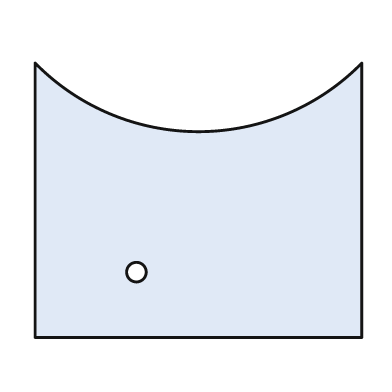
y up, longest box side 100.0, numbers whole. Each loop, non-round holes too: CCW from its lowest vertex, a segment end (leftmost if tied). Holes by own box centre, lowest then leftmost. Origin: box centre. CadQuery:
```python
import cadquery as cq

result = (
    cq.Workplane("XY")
    .moveTo(-50.0, -42.0)
    .lineTo(50.0, -42.0)
    .lineTo(50.0, 42.0)
    .threePointArc((0.0, 21.0), (-50.0, 42.0))
    .close()
    .moveTo(-19.0, -22.0)
    .circle(3.0)
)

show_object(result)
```